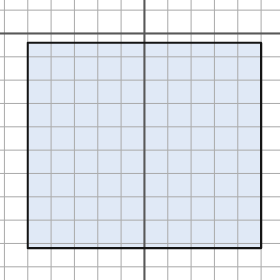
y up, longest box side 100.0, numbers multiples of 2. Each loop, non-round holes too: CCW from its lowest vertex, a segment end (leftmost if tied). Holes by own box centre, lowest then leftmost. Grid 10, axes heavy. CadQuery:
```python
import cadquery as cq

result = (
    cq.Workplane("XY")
    .moveTo(-50.0, -92.0)
    .lineTo(50.0, -92.0)
    .lineTo(50.0, -4.0)
    .lineTo(-50.0, -4.0)
    .close()
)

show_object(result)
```